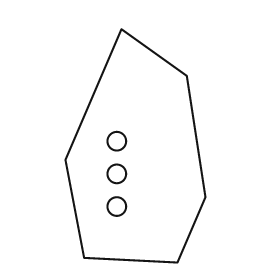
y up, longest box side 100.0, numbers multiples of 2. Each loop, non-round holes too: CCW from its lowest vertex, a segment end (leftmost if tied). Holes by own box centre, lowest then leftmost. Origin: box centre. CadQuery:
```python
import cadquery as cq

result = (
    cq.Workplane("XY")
    .moveTo(18.0, -50.0)
    .lineTo(30.0, -22.0)
    .lineTo(22.0, 30.0)
    .lineTo(-6.0, 50.0)
    .lineTo(-30.0, -6.0)
    .lineTo(-22.0, -48.0)
    .close()
    .moveTo(-8.0, -26.0)
    .circle(4.0)
    .moveTo(-8.0, -12.0)
    .circle(4.0)
    .moveTo(-8.0, 2.0)
    .circle(4.0)
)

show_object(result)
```